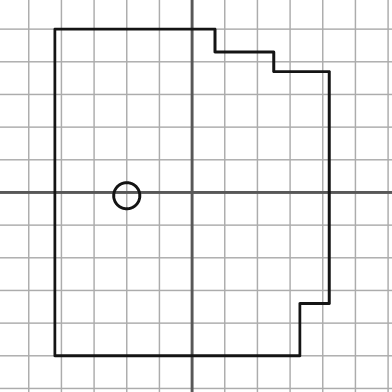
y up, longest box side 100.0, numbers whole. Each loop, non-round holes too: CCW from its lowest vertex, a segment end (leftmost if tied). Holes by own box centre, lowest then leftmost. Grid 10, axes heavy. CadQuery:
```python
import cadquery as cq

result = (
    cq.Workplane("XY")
    .moveTo(-42.0, -50.0)
    .lineTo(33.0, -50.0)
    .lineTo(33.0, -34.0)
    .lineTo(42.0, -34.0)
    .lineTo(42.0, 37.0)
    .lineTo(25.0, 37.0)
    .lineTo(25.0, 43.0)
    .lineTo(7.0, 43.0)
    .lineTo(7.0, 50.0)
    .lineTo(-42.0, 50.0)
    .close()
    .moveTo(-20.0, -1.0)
    .circle(4.0)
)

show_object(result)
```